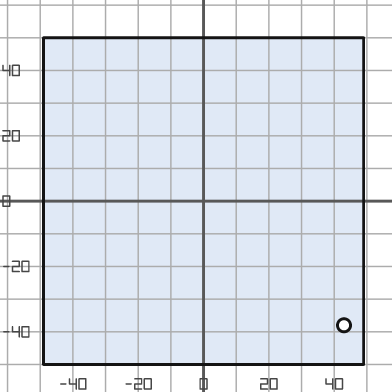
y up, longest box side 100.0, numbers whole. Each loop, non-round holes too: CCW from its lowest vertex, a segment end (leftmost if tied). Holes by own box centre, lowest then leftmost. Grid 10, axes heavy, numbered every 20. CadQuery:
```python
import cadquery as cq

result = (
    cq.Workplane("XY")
    .moveTo(-49.0, -50.0)
    .lineTo(49.0, -50.0)
    .lineTo(49.0, 50.0)
    .lineTo(-49.0, 50.0)
    .close()
    .moveTo(43.0, -38.0)
    .circle(2.0)
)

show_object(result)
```